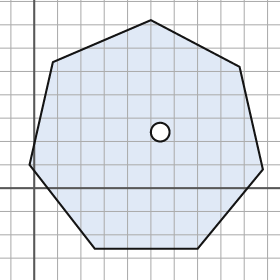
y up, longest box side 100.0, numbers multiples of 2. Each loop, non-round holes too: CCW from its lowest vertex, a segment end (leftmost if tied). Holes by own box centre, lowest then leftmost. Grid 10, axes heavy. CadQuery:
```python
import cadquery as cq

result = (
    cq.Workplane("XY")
    .moveTo(26.0, -26.0)
    .lineTo(70.0, -26.0)
    .lineTo(98.0, 8.0)
    .lineTo(88.0, 52.0)
    .lineTo(50.0, 72.0)
    .lineTo(8.0, 54.0)
    .lineTo(-2.0, 10.0)
    .close()
    .moveTo(54.0, 24.0)
    .circle(4.0)
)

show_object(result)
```